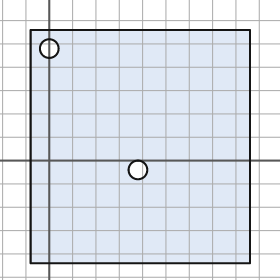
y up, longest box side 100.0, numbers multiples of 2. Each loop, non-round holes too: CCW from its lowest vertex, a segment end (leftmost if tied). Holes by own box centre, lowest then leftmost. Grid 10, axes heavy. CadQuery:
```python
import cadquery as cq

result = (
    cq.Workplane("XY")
    .moveTo(-8.0, -44.0)
    .lineTo(86.0, -44.0)
    .lineTo(86.0, 56.0)
    .lineTo(-8.0, 56.0)
    .close()
    .moveTo(38.0, -4.0)
    .circle(4.0)
    .moveTo(0.0, 48.0)
    .circle(4.0)
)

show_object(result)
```